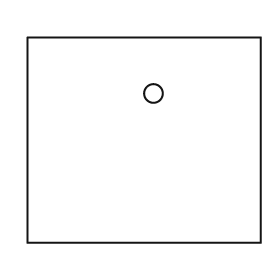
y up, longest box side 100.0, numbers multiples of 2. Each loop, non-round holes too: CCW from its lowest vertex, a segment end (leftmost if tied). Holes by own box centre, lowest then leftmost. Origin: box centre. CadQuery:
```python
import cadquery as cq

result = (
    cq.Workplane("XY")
    .moveTo(-50.0, -44.0)
    .lineTo(50.0, -44.0)
    .lineTo(50.0, 44.0)
    .lineTo(-50.0, 44.0)
    .close()
    .moveTo(4.0, 20.0)
    .circle(4.0)
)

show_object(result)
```